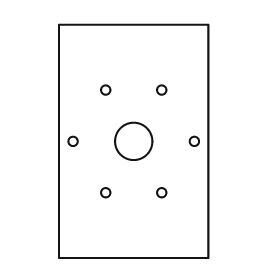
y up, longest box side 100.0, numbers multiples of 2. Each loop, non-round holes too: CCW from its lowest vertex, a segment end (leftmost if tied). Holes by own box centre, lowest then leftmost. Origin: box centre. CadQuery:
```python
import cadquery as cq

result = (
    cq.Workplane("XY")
    .moveTo(-32.0, -50.0)
    .lineTo(32.0, -50.0)
    .lineTo(32.0, 50.0)
    .lineTo(-32.0, 50.0)
    .close()
    .moveTo(-12.0, -22.0)
    .circle(2.0)
    .moveTo(12.0, -22.0)
    .circle(2.0)
    .moveTo(-26.0, 0.0)
    .circle(2.0)
    .moveTo(0.0, 0.0)
    .circle(8.0)
    .moveTo(26.0, 0.0)
    .circle(2.0)
    .moveTo(-12.0, 22.0)
    .circle(2.0)
    .moveTo(12.0, 22.0)
    .circle(2.0)
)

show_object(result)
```